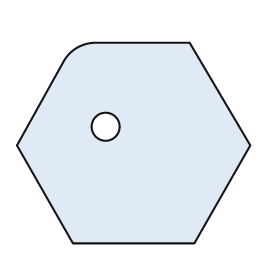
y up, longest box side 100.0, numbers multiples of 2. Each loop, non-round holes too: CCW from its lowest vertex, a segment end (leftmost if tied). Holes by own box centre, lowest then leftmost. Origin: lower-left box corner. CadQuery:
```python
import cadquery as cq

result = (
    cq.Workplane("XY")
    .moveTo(24.0, 0.0)
    .lineTo(76.0, 0.0)
    .lineTo(100.0, 42.0)
    .lineTo(74.0, 86.0)
    .lineTo(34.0, 86.0)
    .threePointArc((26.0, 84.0), (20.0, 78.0))
    .lineTo(0.0, 42.0)
    .close()
    .moveTo(38.0, 50.0)
    .circle(6.0)
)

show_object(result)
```